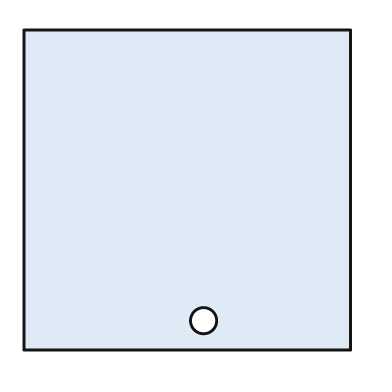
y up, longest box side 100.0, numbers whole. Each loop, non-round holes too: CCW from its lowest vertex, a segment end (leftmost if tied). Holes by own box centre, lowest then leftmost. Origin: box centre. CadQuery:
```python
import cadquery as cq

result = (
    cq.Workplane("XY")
    .moveTo(-50.0, -49.0)
    .lineTo(50.0, -49.0)
    .lineTo(50.0, 49.0)
    .lineTo(-50.0, 49.0)
    .close()
    .moveTo(5.0, -40.0)
    .circle(4.0)
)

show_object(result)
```